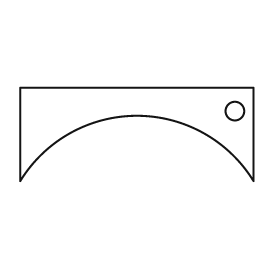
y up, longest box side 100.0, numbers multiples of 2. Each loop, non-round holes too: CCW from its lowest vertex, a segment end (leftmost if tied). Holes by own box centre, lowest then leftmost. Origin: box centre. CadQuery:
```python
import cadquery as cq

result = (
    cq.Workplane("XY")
    .moveTo(-50.0, -20.0)
    .threePointArc((0.0, 8.0), (50.0, -20.0))
    .lineTo(50.0, 20.0)
    .lineTo(-50.0, 20.0)
    .close()
    .moveTo(42.0, 10.0)
    .circle(4.0)
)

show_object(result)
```